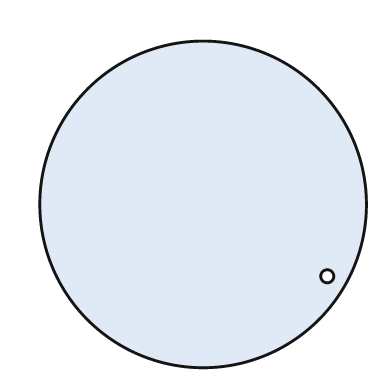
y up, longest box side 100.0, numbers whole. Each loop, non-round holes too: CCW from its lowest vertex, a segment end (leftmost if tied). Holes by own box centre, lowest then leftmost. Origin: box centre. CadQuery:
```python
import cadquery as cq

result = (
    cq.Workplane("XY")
    .moveTo(0.0, 0.0)
    .circle(50.0)
    .moveTo(38.0, -22.0)
    .circle(2.0)
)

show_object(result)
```